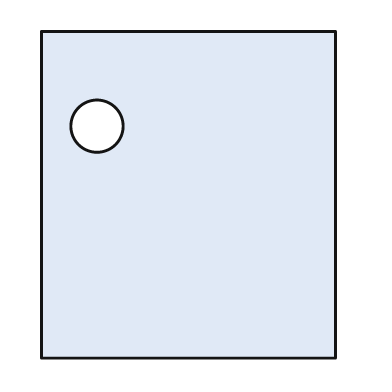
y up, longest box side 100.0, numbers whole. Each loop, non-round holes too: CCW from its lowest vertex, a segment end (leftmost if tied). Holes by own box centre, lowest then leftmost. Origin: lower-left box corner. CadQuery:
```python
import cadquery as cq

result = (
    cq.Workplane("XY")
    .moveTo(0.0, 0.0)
    .lineTo(90.0, 0.0)
    .lineTo(90.0, 100.0)
    .lineTo(0.0, 100.0)
    .close()
    .moveTo(17.0, 71.0)
    .circle(8.0)
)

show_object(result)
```